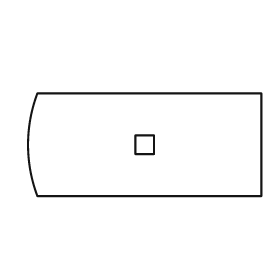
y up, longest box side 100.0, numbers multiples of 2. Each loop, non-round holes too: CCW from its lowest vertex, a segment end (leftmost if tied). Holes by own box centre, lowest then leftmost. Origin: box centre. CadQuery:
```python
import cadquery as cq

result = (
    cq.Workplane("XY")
    .moveTo(-46.0, -22.0)
    .lineTo(50.0, -22.0)
    .lineTo(50.0, 22.0)
    .lineTo(-46.0, 22.0)
    .threePointArc((-50.0, 0.0), (-46.0, -22.0))
    .close()
    .moveTo(-4.0, -4.0)
    .lineTo(4.0, -4.0)
    .lineTo(4.0, 4.0)
    .lineTo(-4.0, 4.0)
    .close()
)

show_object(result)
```